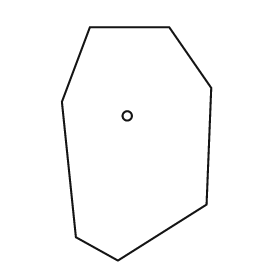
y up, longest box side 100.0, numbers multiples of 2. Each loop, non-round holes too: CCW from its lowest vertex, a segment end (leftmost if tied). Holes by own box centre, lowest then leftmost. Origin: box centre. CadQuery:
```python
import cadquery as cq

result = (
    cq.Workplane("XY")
    .moveTo(-8.0, -50.0)
    .lineTo(30.0, -26.0)
    .lineTo(32.0, 24.0)
    .lineTo(14.0, 50.0)
    .lineTo(-20.0, 50.0)
    .lineTo(-32.0, 18.0)
    .lineTo(-26.0, -40.0)
    .close()
    .moveTo(-4.0, 12.0)
    .circle(2.0)
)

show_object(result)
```